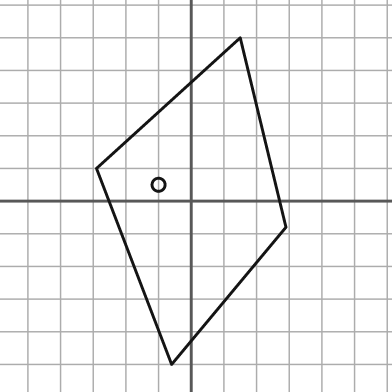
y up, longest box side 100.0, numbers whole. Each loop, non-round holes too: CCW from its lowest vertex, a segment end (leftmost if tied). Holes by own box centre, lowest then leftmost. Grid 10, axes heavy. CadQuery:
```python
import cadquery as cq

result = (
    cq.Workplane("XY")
    .moveTo(-6.0, -50.0)
    .lineTo(29.0, -8.0)
    .lineTo(15.0, 50.0)
    .lineTo(-29.0, 10.0)
    .close()
    .moveTo(-10.0, 5.0)
    .circle(2.0)
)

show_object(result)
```